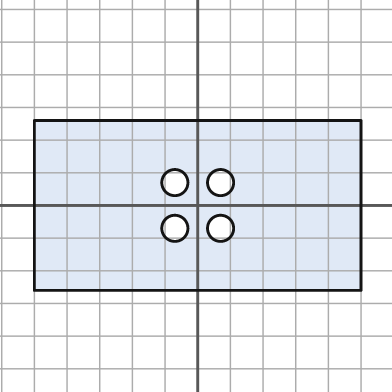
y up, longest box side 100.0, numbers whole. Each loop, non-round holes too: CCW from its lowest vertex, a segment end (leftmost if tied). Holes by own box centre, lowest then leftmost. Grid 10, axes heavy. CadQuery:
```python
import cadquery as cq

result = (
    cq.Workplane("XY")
    .moveTo(-50.0, -26.0)
    .lineTo(50.0, -26.0)
    .lineTo(50.0, 26.0)
    .lineTo(-50.0, 26.0)
    .close()
    .moveTo(-7.0, -7.0)
    .circle(4.0)
    .moveTo(7.0, -7.0)
    .circle(4.0)
    .moveTo(-7.0, 7.0)
    .circle(4.0)
    .moveTo(7.0, 7.0)
    .circle(4.0)
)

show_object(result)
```